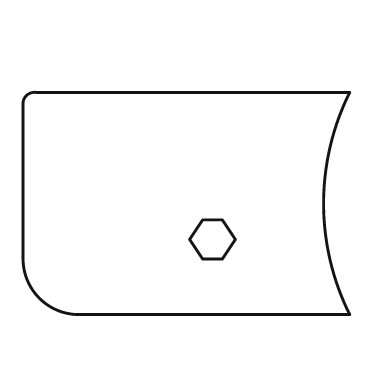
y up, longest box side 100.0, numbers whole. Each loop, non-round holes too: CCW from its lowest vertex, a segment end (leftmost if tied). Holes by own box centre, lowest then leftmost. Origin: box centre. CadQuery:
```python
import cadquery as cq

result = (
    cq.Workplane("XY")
    .moveTo(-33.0, -34.0)
    .lineTo(50.0, -34.0)
    .threePointArc((42.0, 0.0), (50.0, 34.0))
    .lineTo(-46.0, 34.0)
    .threePointArc((-49.0, 33.0), (-50.0, 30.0))
    .lineTo(-50.0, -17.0)
    .threePointArc((-45.0, -29.0), (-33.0, -34.0))
    .close()
    .moveTo(5.0, -17.0)
    .lineTo(11.0, -17.0)
    .lineTo(15.0, -11.0)
    .lineTo(11.0, -5.0)
    .lineTo(5.0, -5.0)
    .lineTo(1.0, -11.0)
    .close()
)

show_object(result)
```